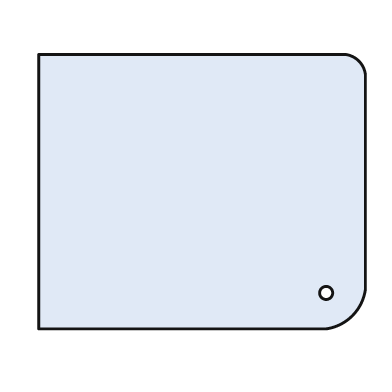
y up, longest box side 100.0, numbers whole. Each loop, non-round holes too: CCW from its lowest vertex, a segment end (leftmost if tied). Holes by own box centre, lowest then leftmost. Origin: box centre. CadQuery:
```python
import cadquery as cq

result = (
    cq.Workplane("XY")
    .moveTo(-50.0, -42.0)
    .lineTo(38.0, -42.0)
    .threePointArc((46.0, -38.0), (50.0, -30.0))
    .lineTo(50.0, 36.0)
    .threePointArc((48.0, 40.0), (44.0, 42.0))
    .lineTo(-50.0, 42.0)
    .close()
    .moveTo(38.0, -31.0)
    .circle(2.0)
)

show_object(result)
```